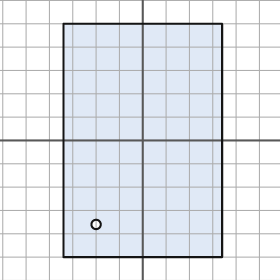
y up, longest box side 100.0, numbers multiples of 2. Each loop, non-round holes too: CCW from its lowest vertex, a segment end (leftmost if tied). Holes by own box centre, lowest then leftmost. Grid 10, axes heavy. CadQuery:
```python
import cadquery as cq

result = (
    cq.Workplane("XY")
    .moveTo(-34.0, -50.0)
    .lineTo(34.0, -50.0)
    .lineTo(34.0, 50.0)
    .lineTo(-34.0, 50.0)
    .close()
    .moveTo(-20.0, -36.0)
    .circle(2.0)
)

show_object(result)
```